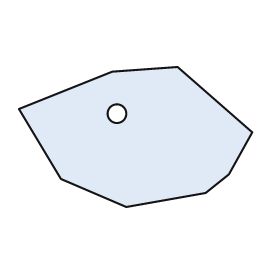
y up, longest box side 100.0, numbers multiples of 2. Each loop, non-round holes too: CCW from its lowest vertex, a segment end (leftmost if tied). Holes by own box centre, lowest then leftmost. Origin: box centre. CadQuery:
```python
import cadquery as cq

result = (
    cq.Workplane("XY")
    .moveTo(-4.0, -30.0)
    .lineTo(30.0, -24.0)
    .lineTo(40.0, -16.0)
    .lineTo(50.0, 2.0)
    .lineTo(18.0, 30.0)
    .lineTo(-10.0, 28.0)
    .lineTo(-50.0, 12.0)
    .lineTo(-32.0, -18.0)
    .close()
    .moveTo(-8.0, 10.0)
    .circle(4.0)
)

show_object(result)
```